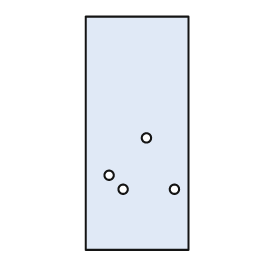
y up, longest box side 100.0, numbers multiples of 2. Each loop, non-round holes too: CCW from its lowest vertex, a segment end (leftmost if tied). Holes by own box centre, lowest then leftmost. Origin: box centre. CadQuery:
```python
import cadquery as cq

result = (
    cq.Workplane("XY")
    .moveTo(-22.0, -50.0)
    .lineTo(22.0, -50.0)
    .lineTo(22.0, 50.0)
    .lineTo(-22.0, 50.0)
    .close()
    .moveTo(-6.0, -24.0)
    .circle(2.0)
    .moveTo(16.0, -24.0)
    .circle(2.0)
    .moveTo(-12.0, -18.0)
    .circle(2.0)
    .moveTo(4.0, -2.0)
    .circle(2.0)
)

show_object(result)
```